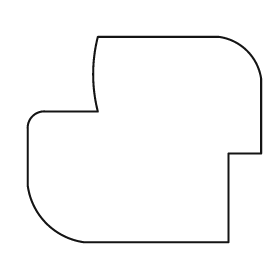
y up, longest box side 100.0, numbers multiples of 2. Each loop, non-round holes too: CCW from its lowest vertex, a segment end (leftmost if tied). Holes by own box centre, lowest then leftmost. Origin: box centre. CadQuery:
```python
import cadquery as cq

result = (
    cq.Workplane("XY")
    .moveTo(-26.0, -44.0)
    .lineTo(36.0, -44.0)
    .lineTo(36.0, -6.0)
    .lineTo(50.0, -6.0)
    .lineTo(50.0, 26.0)
    .threePointArc((44.0, 38.0), (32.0, 44.0))
    .lineTo(-20.0, 44.0)
    .threePointArc((-22.0, 28.0), (-20.0, 12.0))
    .lineTo(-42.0, 12.0)
    .threePointArc((-48.0, 10.0), (-50.0, 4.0))
    .lineTo(-50.0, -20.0)
    .threePointArc((-42.0, -36.0), (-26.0, -44.0))
    .close()
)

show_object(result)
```